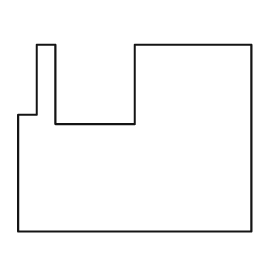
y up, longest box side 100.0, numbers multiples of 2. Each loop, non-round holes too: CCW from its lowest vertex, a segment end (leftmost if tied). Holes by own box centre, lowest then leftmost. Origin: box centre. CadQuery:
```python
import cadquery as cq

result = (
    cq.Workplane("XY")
    .moveTo(-50.0, -40.0)
    .lineTo(50.0, -40.0)
    .lineTo(50.0, 40.0)
    .lineTo(0.0, 40.0)
    .lineTo(0.0, 6.0)
    .lineTo(-34.0, 6.0)
    .lineTo(-34.0, 40.0)
    .lineTo(-42.0, 40.0)
    .lineTo(-42.0, 10.0)
    .lineTo(-50.0, 10.0)
    .close()
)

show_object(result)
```